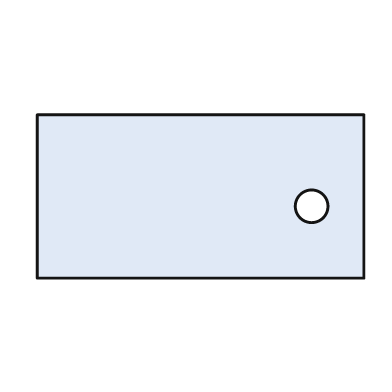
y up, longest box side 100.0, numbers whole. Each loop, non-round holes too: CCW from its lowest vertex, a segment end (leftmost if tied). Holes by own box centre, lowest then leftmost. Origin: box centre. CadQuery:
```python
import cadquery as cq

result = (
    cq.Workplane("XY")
    .moveTo(-50.0, -25.0)
    .lineTo(50.0, -25.0)
    .lineTo(50.0, 25.0)
    .lineTo(-50.0, 25.0)
    .close()
    .moveTo(34.0, -3.0)
    .circle(5.0)
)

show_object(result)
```